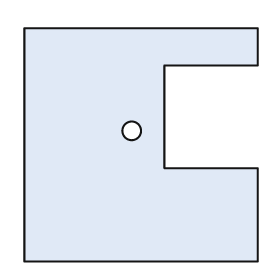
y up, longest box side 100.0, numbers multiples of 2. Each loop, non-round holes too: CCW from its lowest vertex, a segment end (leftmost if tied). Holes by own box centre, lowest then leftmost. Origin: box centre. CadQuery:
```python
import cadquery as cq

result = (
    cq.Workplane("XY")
    .moveTo(-50.0, -50.0)
    .lineTo(50.0, -50.0)
    .lineTo(50.0, -10.0)
    .lineTo(10.0, -10.0)
    .lineTo(10.0, 34.0)
    .lineTo(50.0, 34.0)
    .lineTo(50.0, 50.0)
    .lineTo(-50.0, 50.0)
    .close()
    .moveTo(-4.0, 6.0)
    .circle(4.0)
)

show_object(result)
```